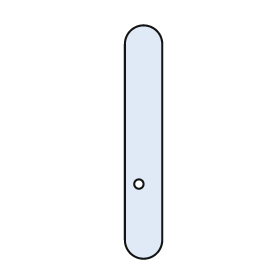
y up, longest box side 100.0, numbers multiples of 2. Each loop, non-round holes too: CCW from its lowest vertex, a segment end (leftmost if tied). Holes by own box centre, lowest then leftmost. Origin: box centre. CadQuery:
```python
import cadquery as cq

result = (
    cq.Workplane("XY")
    .moveTo(-8.0, -42.0)
    .threePointArc((0.0, -50.0), (8.0, -42.0))
    .lineTo(8.0, 42.0)
    .threePointArc((0.0, 50.0), (-8.0, 42.0))
    .close()
    .moveTo(-2.0, -18.0)
    .circle(2.0)
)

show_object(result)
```